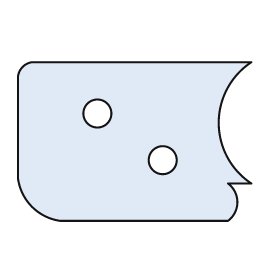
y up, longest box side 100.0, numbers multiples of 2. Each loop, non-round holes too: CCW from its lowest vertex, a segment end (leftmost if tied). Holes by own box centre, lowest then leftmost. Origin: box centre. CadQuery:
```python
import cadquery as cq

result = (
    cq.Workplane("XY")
    .moveTo(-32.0, -34.0)
    .lineTo(40.0, -34.0)
    .threePointArc((44.0, -26.0), (40.0, -18.0))
    .lineTo(50.0, -18.0)
    .threePointArc((36.0, 8.0), (50.0, 34.0))
    .lineTo(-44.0, 34.0)
    .threePointArc((-48.0, 32.0), (-50.0, 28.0))
    .lineTo(-50.0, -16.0)
    .threePointArc((-44.0, -28.0), (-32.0, -34.0))
    .close()
    .moveTo(12.0, -8.0)
    .circle(6.0)
    .moveTo(-16.0, 12.0)
    .circle(6.0)
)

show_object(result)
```